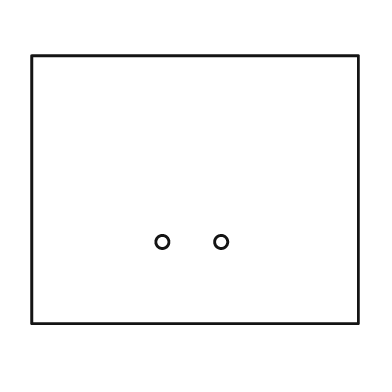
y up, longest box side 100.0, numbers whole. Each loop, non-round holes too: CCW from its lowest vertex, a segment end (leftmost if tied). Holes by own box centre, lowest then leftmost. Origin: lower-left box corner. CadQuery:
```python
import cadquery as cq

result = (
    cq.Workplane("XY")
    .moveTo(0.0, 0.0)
    .lineTo(100.0, 0.0)
    .lineTo(100.0, 82.0)
    .lineTo(0.0, 82.0)
    .close()
    .moveTo(40.0, 25.0)
    .circle(2.0)
    .moveTo(58.0, 25.0)
    .circle(2.0)
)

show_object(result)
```